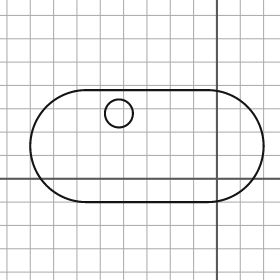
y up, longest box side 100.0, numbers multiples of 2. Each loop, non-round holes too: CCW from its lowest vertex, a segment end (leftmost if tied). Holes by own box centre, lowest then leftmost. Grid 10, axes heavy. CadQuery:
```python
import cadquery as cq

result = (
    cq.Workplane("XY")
    .moveTo(-56.0, -10.0)
    .lineTo(-4.0, -10.0)
    .threePointArc((20.0, 14.0), (-4.0, 38.0))
    .lineTo(-56.0, 38.0)
    .threePointArc((-80.0, 14.0), (-56.0, -10.0))
    .close()
    .moveTo(-42.0, 28.0)
    .circle(6.0)
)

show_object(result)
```